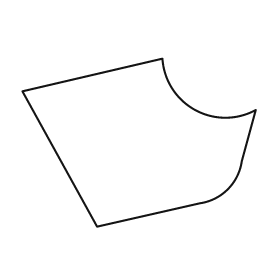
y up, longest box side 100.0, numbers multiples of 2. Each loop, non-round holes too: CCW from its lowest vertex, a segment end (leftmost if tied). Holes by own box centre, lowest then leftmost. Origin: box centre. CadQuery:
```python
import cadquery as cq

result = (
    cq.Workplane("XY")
    .moveTo(-18.0, -36.0)
    .lineTo(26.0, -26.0)
    .threePointArc((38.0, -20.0), (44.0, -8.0))
    .lineTo(50.0, 14.0)
    .threePointArc((24.0, 14.0), (10.0, 36.0))
    .lineTo(-50.0, 22.0)
    .close()
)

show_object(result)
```